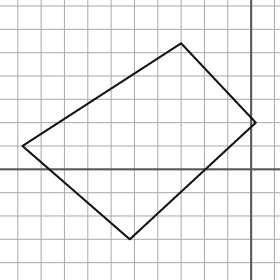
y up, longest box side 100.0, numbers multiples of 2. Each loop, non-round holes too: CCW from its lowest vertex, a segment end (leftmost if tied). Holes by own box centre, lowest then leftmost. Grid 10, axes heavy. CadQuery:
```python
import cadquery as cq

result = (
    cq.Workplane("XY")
    .moveTo(-52.0, -30.0)
    .lineTo(2.0, 20.0)
    .lineTo(-30.0, 54.0)
    .lineTo(-98.0, 10.0)
    .close()
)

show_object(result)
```